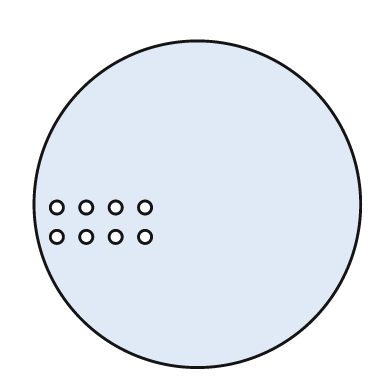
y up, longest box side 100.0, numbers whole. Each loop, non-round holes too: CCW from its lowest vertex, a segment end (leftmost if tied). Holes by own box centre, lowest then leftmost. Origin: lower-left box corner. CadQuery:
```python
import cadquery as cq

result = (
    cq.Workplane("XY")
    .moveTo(50.0, 50.0)
    .circle(50.0)
    .moveTo(7.0, 40.0)
    .circle(2.0)
    .moveTo(16.0, 40.0)
    .circle(2.0)
    .moveTo(25.0, 40.0)
    .circle(2.0)
    .moveTo(34.0, 40.0)
    .circle(2.0)
    .moveTo(7.0, 49.0)
    .circle(2.0)
    .moveTo(16.0, 49.0)
    .circle(2.0)
    .moveTo(25.0, 49.0)
    .circle(2.0)
    .moveTo(34.0, 49.0)
    .circle(2.0)
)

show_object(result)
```